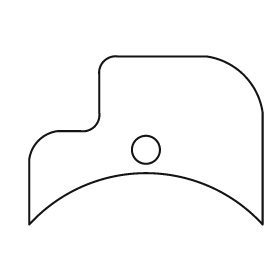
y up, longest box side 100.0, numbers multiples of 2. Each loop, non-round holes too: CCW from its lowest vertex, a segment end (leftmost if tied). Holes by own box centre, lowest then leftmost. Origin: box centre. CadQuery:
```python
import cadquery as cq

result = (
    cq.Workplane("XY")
    .moveTo(-50.0, -36.0)
    .threePointArc((0.0, -14.0), (50.0, -36.0))
    .lineTo(50.0, 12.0)
    .threePointArc((42.0, 28.0), (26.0, 36.0))
    .lineTo(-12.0, 36.0)
    .threePointArc((-18.0, 34.0), (-20.0, 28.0))
    .lineTo(-20.0, 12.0)
    .threePointArc((-22.0, 6.0), (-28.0, 4.0))
    .lineTo(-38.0, 4.0)
    .threePointArc((-46.0, 0.0), (-50.0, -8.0))
    .close()
    .moveTo(0.0, -4.0)
    .circle(6.0)
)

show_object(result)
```